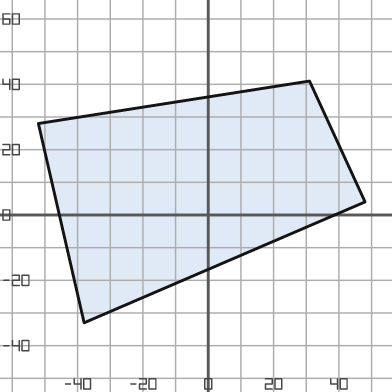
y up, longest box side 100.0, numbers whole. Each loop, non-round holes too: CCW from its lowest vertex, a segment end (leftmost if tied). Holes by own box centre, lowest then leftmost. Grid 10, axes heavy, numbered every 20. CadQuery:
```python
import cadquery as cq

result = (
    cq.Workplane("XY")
    .moveTo(-38.0, -33.0)
    .lineTo(48.0, 4.0)
    .lineTo(31.0, 41.0)
    .lineTo(-52.0, 28.0)
    .close()
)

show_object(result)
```